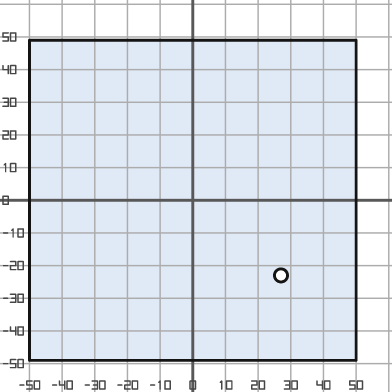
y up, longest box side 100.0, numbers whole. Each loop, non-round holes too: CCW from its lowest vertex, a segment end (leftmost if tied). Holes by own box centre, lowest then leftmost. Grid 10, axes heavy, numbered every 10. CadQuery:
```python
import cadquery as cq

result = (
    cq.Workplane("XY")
    .moveTo(-50.0, -49.0)
    .lineTo(50.0, -49.0)
    .lineTo(50.0, 49.0)
    .lineTo(-50.0, 49.0)
    .close()
    .moveTo(27.0, -23.0)
    .circle(2.0)
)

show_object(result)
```